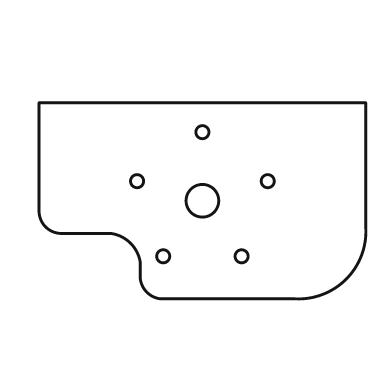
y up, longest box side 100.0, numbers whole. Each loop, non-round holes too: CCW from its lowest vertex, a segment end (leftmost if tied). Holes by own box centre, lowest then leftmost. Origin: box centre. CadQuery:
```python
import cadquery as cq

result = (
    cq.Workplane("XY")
    .moveTo(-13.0, -30.0)
    .lineTo(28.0, -30.0)
    .threePointArc((44.0, -24.0), (50.0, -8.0))
    .lineTo(50.0, 30.0)
    .lineTo(-50.0, 30.0)
    .lineTo(-50.0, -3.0)
    .threePointArc((-48.0, -8.0), (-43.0, -10.0))
    .lineTo(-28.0, -10.0)
    .threePointArc((-22.0, -13.0), (-19.0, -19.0))
    .lineTo(-19.0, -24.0)
    .threePointArc((-17.0, -28.0), (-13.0, -30.0))
    .close()
    .moveTo(-12.0, -17.0)
    .circle(2.0)
    .moveTo(12.0, -17.0)
    .circle(2.0)
    .moveTo(0.0, 0.0)
    .circle(5.0)
    .moveTo(-20.0, 6.0)
    .circle(2.0)
    .moveTo(20.0, 6.0)
    .circle(2.0)
    .moveTo(0.0, 21.0)
    .circle(2.0)
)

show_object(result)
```